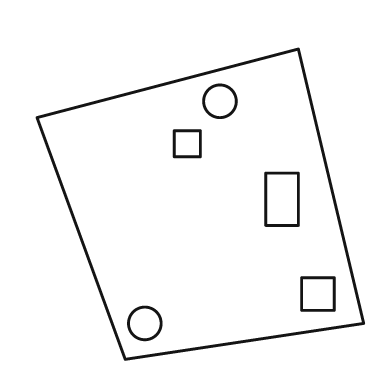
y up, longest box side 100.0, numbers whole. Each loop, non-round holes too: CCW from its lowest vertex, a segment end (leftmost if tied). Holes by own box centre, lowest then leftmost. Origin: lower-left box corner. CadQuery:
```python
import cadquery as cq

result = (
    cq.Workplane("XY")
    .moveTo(27.0, 0.0)
    .lineTo(100.0, 11.0)
    .lineTo(80.0, 95.0)
    .lineTo(0.0, 74.0)
    .close()
    .moveTo(33.0, 11.0)
    .circle(5.0)
    .moveTo(81.0, 15.0)
    .lineTo(91.0, 15.0)
    .lineTo(91.0, 25.0)
    .lineTo(81.0, 25.0)
    .close()
    .moveTo(70.0, 41.0)
    .lineTo(80.0, 41.0)
    .lineTo(80.0, 57.0)
    .lineTo(70.0, 57.0)
    .close()
    .moveTo(42.0, 62.0)
    .lineTo(50.0, 62.0)
    .lineTo(50.0, 70.0)
    .lineTo(42.0, 70.0)
    .close()
    .moveTo(56.0, 79.0)
    .circle(5.0)
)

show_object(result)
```